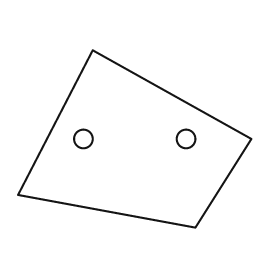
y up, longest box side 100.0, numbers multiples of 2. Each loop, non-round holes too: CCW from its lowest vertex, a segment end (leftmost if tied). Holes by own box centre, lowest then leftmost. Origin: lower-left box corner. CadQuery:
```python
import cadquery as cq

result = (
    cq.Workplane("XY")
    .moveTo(76.0, 0.0)
    .lineTo(100.0, 38.0)
    .lineTo(32.0, 76.0)
    .lineTo(0.0, 14.0)
    .close()
    .moveTo(28.0, 38.0)
    .circle(4.0)
    .moveTo(72.0, 38.0)
    .circle(4.0)
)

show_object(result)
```